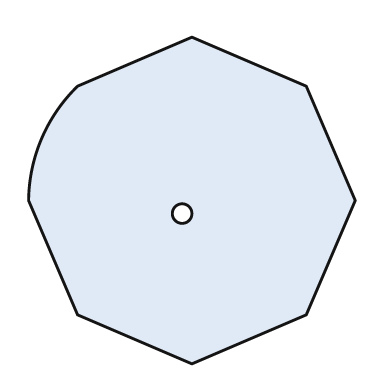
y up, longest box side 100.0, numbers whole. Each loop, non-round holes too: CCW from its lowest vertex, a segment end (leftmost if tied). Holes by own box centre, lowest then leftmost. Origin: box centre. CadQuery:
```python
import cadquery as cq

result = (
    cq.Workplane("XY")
    .moveTo(0.0, -50.0)
    .lineTo(35.0, -35.0)
    .lineTo(50.0, 0.0)
    .lineTo(35.0, 35.0)
    .lineTo(0.0, 50.0)
    .lineTo(-35.0, 35.0)
    .threePointArc((-46.0, 19.0), (-50.0, 0.0))
    .lineTo(-35.0, -35.0)
    .close()
    .moveTo(-3.0, -4.0)
    .circle(3.0)
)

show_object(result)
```